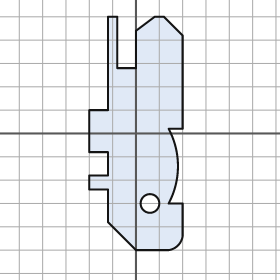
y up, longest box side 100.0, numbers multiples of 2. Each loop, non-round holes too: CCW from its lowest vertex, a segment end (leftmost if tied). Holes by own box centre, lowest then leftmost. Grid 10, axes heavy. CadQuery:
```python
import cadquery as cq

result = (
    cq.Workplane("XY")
    .moveTo(0.0, -50.0)
    .lineTo(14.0, -50.0)
    .threePointArc((18.0, -48.0), (20.0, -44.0))
    .lineTo(20.0, -30.0)
    .lineTo(14.0, -30.0)
    .threePointArc((18.0, -14.0), (14.0, 2.0))
    .lineTo(20.0, 2.0)
    .lineTo(20.0, 42.0)
    .lineTo(12.0, 50.0)
    .lineTo(8.0, 50.0)
    .lineTo(0.0, 44.0)
    .lineTo(0.0, 28.0)
    .lineTo(-8.0, 28.0)
    .lineTo(-8.0, 50.0)
    .lineTo(-12.0, 50.0)
    .lineTo(-12.0, 10.0)
    .lineTo(-20.0, 10.0)
    .lineTo(-20.0, -8.0)
    .lineTo(-12.0, -8.0)
    .lineTo(-12.0, -18.0)
    .lineTo(-20.0, -18.0)
    .lineTo(-20.0, -24.0)
    .lineTo(-12.0, -24.0)
    .lineTo(-12.0, -38.0)
    .close()
    .moveTo(6.0, -30.0)
    .circle(4.0)
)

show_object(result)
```